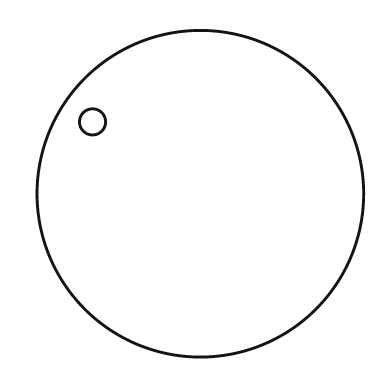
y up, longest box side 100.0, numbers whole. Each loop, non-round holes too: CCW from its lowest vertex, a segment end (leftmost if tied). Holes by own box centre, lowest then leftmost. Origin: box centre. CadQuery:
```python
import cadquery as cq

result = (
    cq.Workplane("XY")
    .moveTo(0.0, 0.0)
    .circle(50.0)
    .moveTo(-33.0, 22.0)
    .circle(4.0)
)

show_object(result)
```